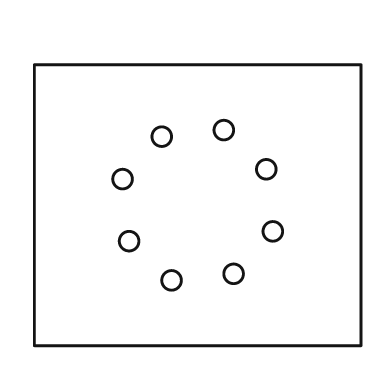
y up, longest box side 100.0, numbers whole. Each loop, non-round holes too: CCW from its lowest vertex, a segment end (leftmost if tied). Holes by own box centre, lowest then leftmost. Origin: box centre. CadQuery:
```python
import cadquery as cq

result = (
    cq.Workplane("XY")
    .moveTo(-50.0, -43.0)
    .lineTo(50.0, -43.0)
    .lineTo(50.0, 43.0)
    .lineTo(-50.0, 43.0)
    .close()
    .moveTo(-8.0, -23.0)
    .circle(3.0)
    .moveTo(11.0, -21.0)
    .circle(3.0)
    .moveTo(-21.0, -11.0)
    .circle(3.0)
    .moveTo(23.0, -8.0)
    .circle(3.0)
    .moveTo(-23.0, 8.0)
    .circle(3.0)
    .moveTo(21.0, 11.0)
    .circle(3.0)
    .moveTo(-11.0, 21.0)
    .circle(3.0)
    .moveTo(8.0, 23.0)
    .circle(3.0)
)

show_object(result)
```